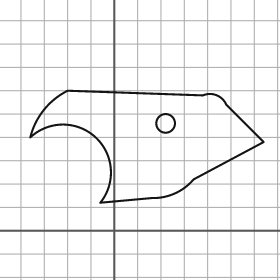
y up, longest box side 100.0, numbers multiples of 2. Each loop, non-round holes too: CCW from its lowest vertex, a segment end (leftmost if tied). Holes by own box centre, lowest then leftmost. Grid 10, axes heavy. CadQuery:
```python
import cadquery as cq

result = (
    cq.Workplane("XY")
    .moveTo(-6.0, 12.0)
    .lineTo(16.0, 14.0)
    .threePointArc((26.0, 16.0), (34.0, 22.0))
    .lineTo(64.0, 38.0)
    .lineTo(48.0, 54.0)
    .threePointArc((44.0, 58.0), (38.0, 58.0))
    .lineTo(-20.0, 60.0)
    .threePointArc((-30.0, 52.0), (-36.0, 40.0))
    .threePointArc((-8.0, 40.0), (-6.0, 12.0))
    .close()
    .moveTo(22.0, 46.0)
    .circle(4.0)
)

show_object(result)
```